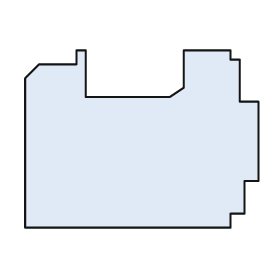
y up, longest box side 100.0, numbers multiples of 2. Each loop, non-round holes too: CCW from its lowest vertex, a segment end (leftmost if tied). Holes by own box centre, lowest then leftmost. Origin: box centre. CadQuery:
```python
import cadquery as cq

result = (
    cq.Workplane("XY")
    .moveTo(-50.0, -38.0)
    .lineTo(38.0, -38.0)
    .lineTo(38.0, -32.0)
    .lineTo(44.0, -32.0)
    .lineTo(44.0, -18.0)
    .lineTo(50.0, -18.0)
    .lineTo(50.0, 16.0)
    .lineTo(42.0, 16.0)
    .lineTo(42.0, 34.0)
    .lineTo(38.0, 34.0)
    .lineTo(38.0, 38.0)
    .lineTo(18.0, 38.0)
    .lineTo(18.0, 22.0)
    .lineTo(12.0, 18.0)
    .lineTo(-24.0, 18.0)
    .lineTo(-24.0, 38.0)
    .lineTo(-28.0, 38.0)
    .lineTo(-28.0, 32.0)
    .lineTo(-44.0, 32.0)
    .lineTo(-50.0, 26.0)
    .close()
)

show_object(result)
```